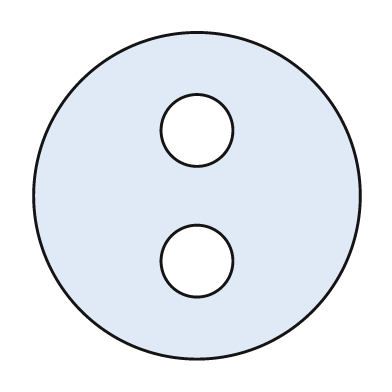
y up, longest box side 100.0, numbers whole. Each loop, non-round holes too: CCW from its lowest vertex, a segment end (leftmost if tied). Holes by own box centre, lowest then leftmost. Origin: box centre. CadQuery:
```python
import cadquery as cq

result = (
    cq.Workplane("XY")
    .moveTo(0.0, 0.0)
    .circle(50.0)
    .moveTo(0.0, -20.0)
    .circle(11.0)
    .moveTo(0.0, 20.0)
    .circle(11.0)
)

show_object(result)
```